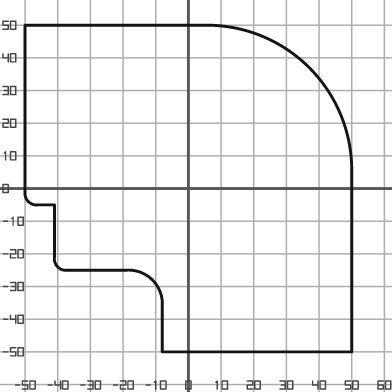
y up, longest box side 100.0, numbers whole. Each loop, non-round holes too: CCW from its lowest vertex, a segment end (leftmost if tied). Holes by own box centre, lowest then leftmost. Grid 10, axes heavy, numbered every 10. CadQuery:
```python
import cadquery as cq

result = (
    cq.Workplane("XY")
    .moveTo(-8.0, -50.0)
    .lineTo(50.0, -50.0)
    .lineTo(50.0, 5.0)
    .threePointArc((37.0, 37.0), (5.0, 50.0))
    .lineTo(-50.0, 50.0)
    .lineTo(-50.0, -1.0)
    .threePointArc((-49.0, -4.0), (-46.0, -5.0))
    .lineTo(-41.0, -5.0)
    .lineTo(-41.0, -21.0)
    .threePointArc((-40.0, -24.0), (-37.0, -25.0))
    .lineTo(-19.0, -25.0)
    .threePointArc((-11.0, -28.0), (-8.0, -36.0))
    .close()
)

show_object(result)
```